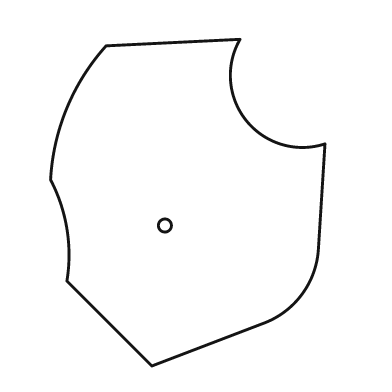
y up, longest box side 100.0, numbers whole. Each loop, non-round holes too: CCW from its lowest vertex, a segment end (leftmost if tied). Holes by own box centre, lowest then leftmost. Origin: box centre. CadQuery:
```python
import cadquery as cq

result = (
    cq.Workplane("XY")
    .moveTo(-11.0, -50.0)
    .lineTo(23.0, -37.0)
    .threePointArc((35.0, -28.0), (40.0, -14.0))
    .lineTo(42.0, 18.0)
    .threePointArc((18.0, 25.0), (16.0, 50.0))
    .lineTo(-25.0, 48.0)
    .threePointArc((-37.0, 29.0), (-42.0, 7.0))
    .threePointArc((-37.0, -8.0), (-37.0, -24.0))
    .close()
    .moveTo(-7.0, -7.0)
    .circle(2.0)
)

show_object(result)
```